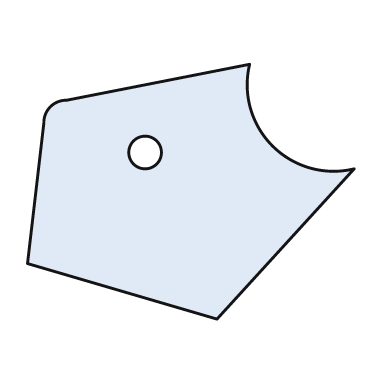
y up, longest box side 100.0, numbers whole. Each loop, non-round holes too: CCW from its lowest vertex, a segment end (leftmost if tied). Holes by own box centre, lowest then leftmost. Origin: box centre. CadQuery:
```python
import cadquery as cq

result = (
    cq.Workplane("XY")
    .moveTo(8.0, -39.0)
    .lineTo(50.0, 7.0)
    .threePointArc((25.0, 14.0), (18.0, 39.0))
    .lineTo(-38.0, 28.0)
    .threePointArc((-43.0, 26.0), (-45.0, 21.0))
    .lineTo(-50.0, -22.0)
    .close()
    .moveTo(-14.0, 12.0)
    .circle(5.0)
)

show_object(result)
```